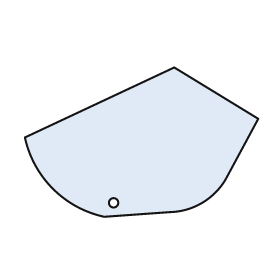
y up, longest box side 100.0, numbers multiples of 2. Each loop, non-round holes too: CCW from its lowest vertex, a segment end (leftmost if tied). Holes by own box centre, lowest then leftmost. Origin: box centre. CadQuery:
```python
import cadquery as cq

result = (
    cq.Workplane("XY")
    .moveTo(-16.0, -32.0)
    .lineTo(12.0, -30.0)
    .threePointArc((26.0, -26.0), (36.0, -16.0))
    .lineTo(50.0, 10.0)
    .lineTo(14.0, 32.0)
    .lineTo(-50.0, 2.0)
    .threePointArc((-38.0, -20.0), (-16.0, -32.0))
    .close()
    .moveTo(-12.0, -26.0)
    .circle(2.0)
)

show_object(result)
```